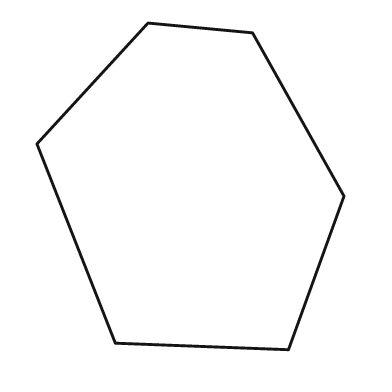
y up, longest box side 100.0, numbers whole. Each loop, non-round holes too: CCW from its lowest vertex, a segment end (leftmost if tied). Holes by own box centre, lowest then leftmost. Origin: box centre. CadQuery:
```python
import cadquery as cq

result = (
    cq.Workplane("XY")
    .moveTo(30.0, -50.0)
    .lineTo(47.0, -3.0)
    .lineTo(19.0, 47.0)
    .lineTo(-13.0, 50.0)
    .lineTo(-47.0, 13.0)
    .lineTo(-23.0, -48.0)
    .close()
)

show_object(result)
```